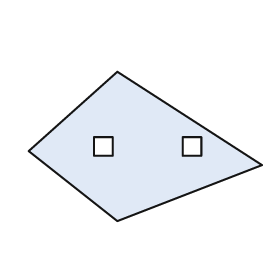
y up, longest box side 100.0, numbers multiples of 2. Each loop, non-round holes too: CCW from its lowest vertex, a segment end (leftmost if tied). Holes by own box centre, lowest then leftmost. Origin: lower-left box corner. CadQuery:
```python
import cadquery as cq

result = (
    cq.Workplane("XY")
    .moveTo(38.0, 0.0)
    .lineTo(100.0, 24.0)
    .lineTo(38.0, 64.0)
    .lineTo(0.0, 30.0)
    .close()
    .moveTo(28.0, 28.0)
    .lineTo(36.0, 28.0)
    .lineTo(36.0, 36.0)
    .lineTo(28.0, 36.0)
    .close()
    .moveTo(66.0, 28.0)
    .lineTo(74.0, 28.0)
    .lineTo(74.0, 36.0)
    .lineTo(66.0, 36.0)
    .close()
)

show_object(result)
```